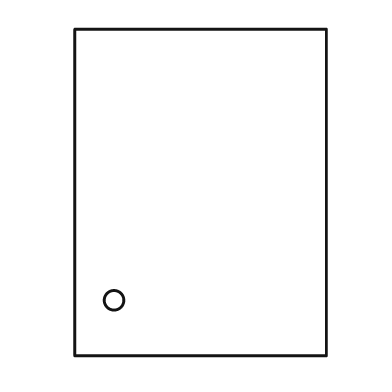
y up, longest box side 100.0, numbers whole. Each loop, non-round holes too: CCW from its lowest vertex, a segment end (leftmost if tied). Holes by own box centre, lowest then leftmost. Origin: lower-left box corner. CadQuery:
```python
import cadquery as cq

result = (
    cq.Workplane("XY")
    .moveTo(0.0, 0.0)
    .lineTo(77.0, 0.0)
    .lineTo(77.0, 100.0)
    .lineTo(0.0, 100.0)
    .close()
    .moveTo(12.0, 17.0)
    .circle(3.0)
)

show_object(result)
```